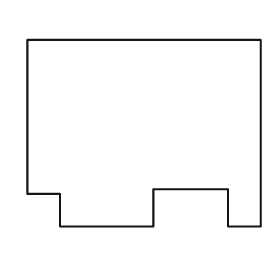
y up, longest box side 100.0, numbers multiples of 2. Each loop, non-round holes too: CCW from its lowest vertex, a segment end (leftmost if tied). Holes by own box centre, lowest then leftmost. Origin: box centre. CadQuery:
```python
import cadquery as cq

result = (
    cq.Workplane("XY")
    .moveTo(-36.0, -40.0)
    .lineTo(4.0, -40.0)
    .lineTo(4.0, -24.0)
    .lineTo(36.0, -24.0)
    .lineTo(36.0, -40.0)
    .lineTo(50.0, -40.0)
    .lineTo(50.0, 40.0)
    .lineTo(-50.0, 40.0)
    .lineTo(-50.0, -26.0)
    .lineTo(-36.0, -26.0)
    .close()
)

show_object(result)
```